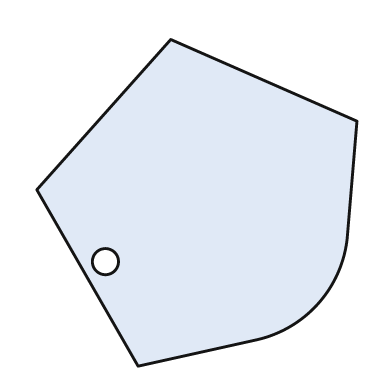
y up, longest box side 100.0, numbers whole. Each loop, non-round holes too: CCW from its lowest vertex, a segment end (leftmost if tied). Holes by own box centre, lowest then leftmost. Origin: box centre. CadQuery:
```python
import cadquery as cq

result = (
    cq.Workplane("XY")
    .moveTo(-18.0, -50.0)
    .lineTo(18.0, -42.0)
    .threePointArc((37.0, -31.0), (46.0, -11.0))
    .lineTo(49.0, 25.0)
    .lineTo(-8.0, 50.0)
    .lineTo(-49.0, 4.0)
    .close()
    .moveTo(-28.0, -18.0)
    .circle(4.0)
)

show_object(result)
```